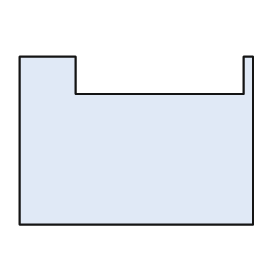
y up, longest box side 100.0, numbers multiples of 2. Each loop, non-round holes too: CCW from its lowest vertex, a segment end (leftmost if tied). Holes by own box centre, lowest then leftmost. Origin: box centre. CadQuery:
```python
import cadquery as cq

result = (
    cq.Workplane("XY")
    .moveTo(-50.0, -36.0)
    .lineTo(50.0, -36.0)
    .lineTo(50.0, 36.0)
    .lineTo(46.0, 36.0)
    .lineTo(46.0, 20.0)
    .lineTo(-26.0, 20.0)
    .lineTo(-26.0, 36.0)
    .lineTo(-50.0, 36.0)
    .close()
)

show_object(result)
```